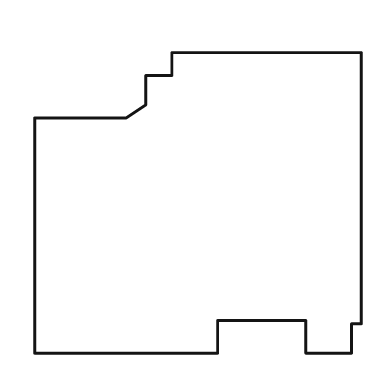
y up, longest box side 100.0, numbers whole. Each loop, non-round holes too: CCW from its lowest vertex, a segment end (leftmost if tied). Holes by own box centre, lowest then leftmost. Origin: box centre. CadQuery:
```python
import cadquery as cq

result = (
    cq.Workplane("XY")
    .moveTo(-50.0, -46.0)
    .lineTo(6.0, -46.0)
    .lineTo(6.0, -36.0)
    .lineTo(33.0, -36.0)
    .lineTo(33.0, -46.0)
    .lineTo(47.0, -46.0)
    .lineTo(47.0, -37.0)
    .lineTo(50.0, -37.0)
    .lineTo(50.0, 46.0)
    .lineTo(-8.0, 46.0)
    .lineTo(-8.0, 39.0)
    .lineTo(-16.0, 39.0)
    .lineTo(-16.0, 30.0)
    .lineTo(-22.0, 26.0)
    .lineTo(-50.0, 26.0)
    .close()
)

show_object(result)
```